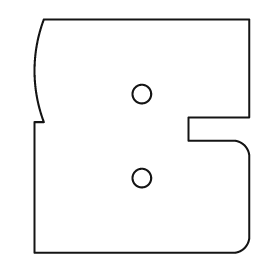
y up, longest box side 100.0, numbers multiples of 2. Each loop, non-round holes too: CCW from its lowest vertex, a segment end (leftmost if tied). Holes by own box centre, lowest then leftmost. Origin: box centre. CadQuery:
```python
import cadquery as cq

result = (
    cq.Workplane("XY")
    .moveTo(-46.0, -50.0)
    .lineTo(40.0, -50.0)
    .threePointArc((44.0, -48.0), (46.0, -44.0))
    .lineTo(46.0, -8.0)
    .threePointArc((44.0, -4.0), (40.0, -2.0))
    .lineTo(20.0, -2.0)
    .lineTo(20.0, 8.0)
    .lineTo(46.0, 8.0)
    .lineTo(46.0, 50.0)
    .lineTo(-42.0, 50.0)
    .threePointArc((-46.0, 28.0), (-42.0, 6.0))
    .lineTo(-46.0, 6.0)
    .close()
    .moveTo(0.0, -18.0)
    .circle(4.0)
    .moveTo(0.0, 18.0)
    .circle(4.0)
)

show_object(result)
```